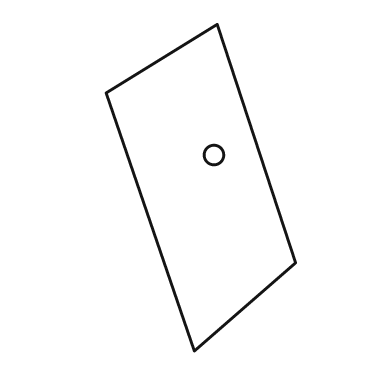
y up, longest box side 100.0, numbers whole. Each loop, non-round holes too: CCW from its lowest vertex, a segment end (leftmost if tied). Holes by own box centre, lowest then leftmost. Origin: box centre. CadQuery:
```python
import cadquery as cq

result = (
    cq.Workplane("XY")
    .moveTo(-2.0, -50.0)
    .lineTo(29.0, -23.0)
    .lineTo(5.0, 50.0)
    .lineTo(-29.0, 29.0)
    .close()
    .moveTo(4.0, 10.0)
    .circle(3.0)
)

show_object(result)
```